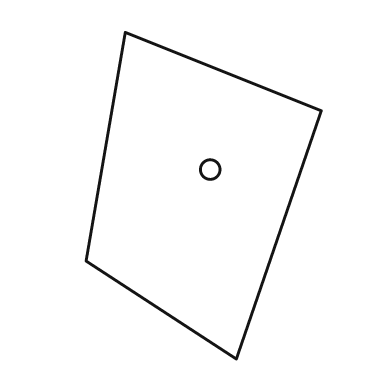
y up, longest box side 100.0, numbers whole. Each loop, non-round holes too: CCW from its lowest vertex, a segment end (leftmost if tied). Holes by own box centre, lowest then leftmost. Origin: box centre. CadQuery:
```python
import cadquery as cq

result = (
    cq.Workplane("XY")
    .moveTo(10.0, -50.0)
    .lineTo(36.0, 26.0)
    .lineTo(-24.0, 50.0)
    .lineTo(-36.0, -20.0)
    .close()
    .moveTo(2.0, 8.0)
    .circle(3.0)
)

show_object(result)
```